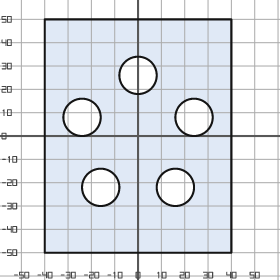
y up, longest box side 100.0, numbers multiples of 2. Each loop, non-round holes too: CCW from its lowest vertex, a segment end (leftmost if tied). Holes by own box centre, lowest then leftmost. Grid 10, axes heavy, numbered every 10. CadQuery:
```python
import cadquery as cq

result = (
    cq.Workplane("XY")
    .moveTo(-40.0, -50.0)
    .lineTo(40.0, -50.0)
    .lineTo(40.0, 50.0)
    .lineTo(-40.0, 50.0)
    .close()
    .moveTo(-16.0, -22.0)
    .circle(8.0)
    .moveTo(16.0, -22.0)
    .circle(8.0)
    .moveTo(-24.0, 8.0)
    .circle(8.0)
    .moveTo(24.0, 8.0)
    .circle(8.0)
    .moveTo(0.0, 26.0)
    .circle(8.0)
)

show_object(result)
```